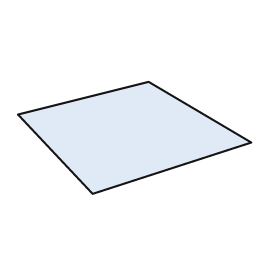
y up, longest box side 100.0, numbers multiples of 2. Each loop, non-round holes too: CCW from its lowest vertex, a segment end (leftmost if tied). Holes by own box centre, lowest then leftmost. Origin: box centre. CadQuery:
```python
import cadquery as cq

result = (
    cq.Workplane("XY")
    .moveTo(-18.0, -24.0)
    .lineTo(50.0, -2.0)
    .lineTo(6.0, 24.0)
    .lineTo(-50.0, 10.0)
    .close()
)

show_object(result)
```